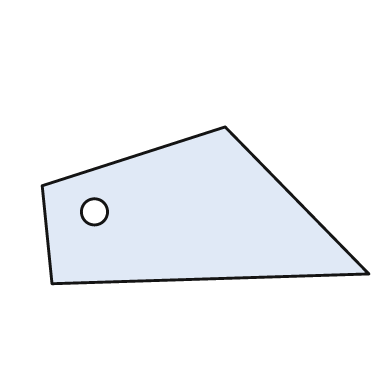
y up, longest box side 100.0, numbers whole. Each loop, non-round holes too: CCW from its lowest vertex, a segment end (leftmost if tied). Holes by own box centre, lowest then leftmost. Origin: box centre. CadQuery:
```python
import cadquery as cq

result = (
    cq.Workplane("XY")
    .moveTo(-47.0, -24.0)
    .lineTo(50.0, -21.0)
    .lineTo(6.0, 24.0)
    .lineTo(-50.0, 6.0)
    .close()
    .moveTo(-34.0, -2.0)
    .circle(4.0)
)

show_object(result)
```